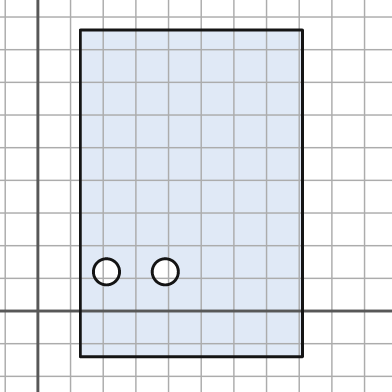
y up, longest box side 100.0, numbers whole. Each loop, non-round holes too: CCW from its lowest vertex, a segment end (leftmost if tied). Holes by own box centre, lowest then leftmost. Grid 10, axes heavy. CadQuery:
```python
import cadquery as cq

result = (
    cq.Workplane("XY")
    .moveTo(13.0, -14.0)
    .lineTo(81.0, -14.0)
    .lineTo(81.0, 86.0)
    .lineTo(13.0, 86.0)
    .close()
    .moveTo(21.0, 12.0)
    .circle(4.0)
    .moveTo(39.0, 12.0)
    .circle(4.0)
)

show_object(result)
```